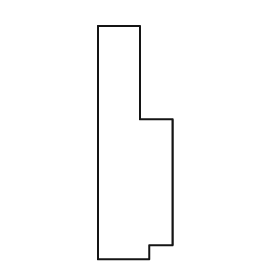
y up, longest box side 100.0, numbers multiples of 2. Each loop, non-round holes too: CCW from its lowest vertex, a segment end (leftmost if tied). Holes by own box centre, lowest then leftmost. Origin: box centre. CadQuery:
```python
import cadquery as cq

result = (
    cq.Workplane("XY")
    .moveTo(-16.0, -50.0)
    .lineTo(6.0, -50.0)
    .lineTo(6.0, -44.0)
    .lineTo(16.0, -44.0)
    .lineTo(16.0, 10.0)
    .lineTo(2.0, 10.0)
    .lineTo(2.0, 50.0)
    .lineTo(-16.0, 50.0)
    .close()
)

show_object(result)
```